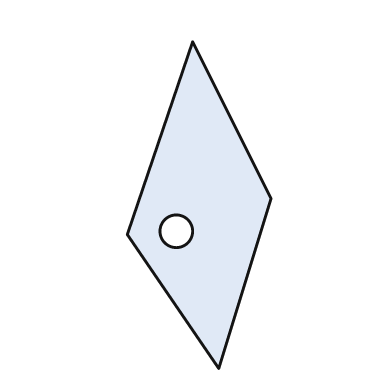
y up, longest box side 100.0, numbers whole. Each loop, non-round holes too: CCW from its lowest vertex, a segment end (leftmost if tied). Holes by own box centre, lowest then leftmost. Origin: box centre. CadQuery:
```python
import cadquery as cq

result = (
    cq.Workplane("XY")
    .moveTo(6.0, -50.0)
    .lineTo(22.0, 2.0)
    .lineTo(-2.0, 50.0)
    .lineTo(-22.0, -9.0)
    .close()
    .moveTo(-7.0, -8.0)
    .circle(5.0)
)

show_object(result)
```